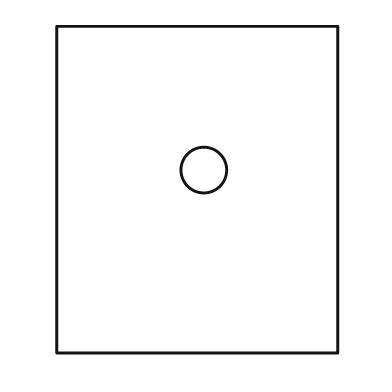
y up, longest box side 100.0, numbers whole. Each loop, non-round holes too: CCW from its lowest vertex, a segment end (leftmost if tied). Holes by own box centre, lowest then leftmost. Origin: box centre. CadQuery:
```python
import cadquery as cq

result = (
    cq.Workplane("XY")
    .moveTo(-43.0, -50.0)
    .lineTo(43.0, -50.0)
    .lineTo(43.0, 50.0)
    .lineTo(-43.0, 50.0)
    .close()
    .moveTo(2.0, 6.0)
    .circle(7.0)
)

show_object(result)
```